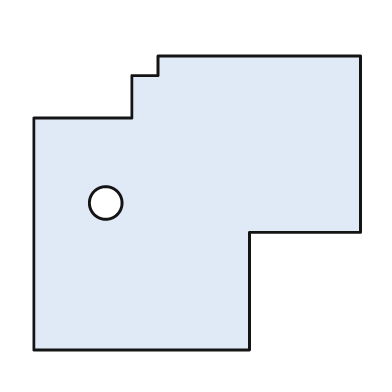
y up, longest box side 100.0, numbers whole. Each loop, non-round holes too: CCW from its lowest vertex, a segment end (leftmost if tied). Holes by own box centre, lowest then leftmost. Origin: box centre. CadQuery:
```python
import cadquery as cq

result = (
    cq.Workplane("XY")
    .moveTo(-50.0, -45.0)
    .lineTo(16.0, -45.0)
    .lineTo(16.0, -9.0)
    .lineTo(50.0, -9.0)
    .lineTo(50.0, 45.0)
    .lineTo(-12.0, 45.0)
    .lineTo(-12.0, 39.0)
    .lineTo(-20.0, 39.0)
    .lineTo(-20.0, 26.0)
    .lineTo(-50.0, 26.0)
    .close()
    .moveTo(-28.0, 0.0)
    .circle(5.0)
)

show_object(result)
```